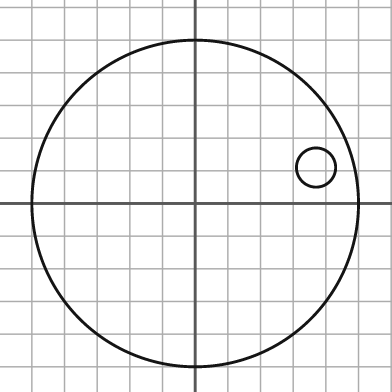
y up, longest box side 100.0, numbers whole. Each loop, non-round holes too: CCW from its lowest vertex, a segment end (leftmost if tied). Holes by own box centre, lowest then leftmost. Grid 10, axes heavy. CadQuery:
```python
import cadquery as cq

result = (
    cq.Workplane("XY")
    .moveTo(0.0, 0.0)
    .circle(50.0)
    .moveTo(37.0, 11.0)
    .circle(6.0)
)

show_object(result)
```